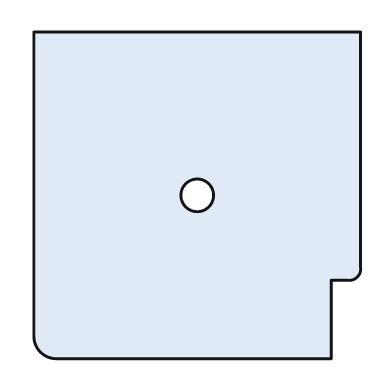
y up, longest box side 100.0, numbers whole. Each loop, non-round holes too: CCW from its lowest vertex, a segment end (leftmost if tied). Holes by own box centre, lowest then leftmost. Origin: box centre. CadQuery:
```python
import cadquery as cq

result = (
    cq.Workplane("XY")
    .moveTo(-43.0, -50.0)
    .lineTo(41.0, -50.0)
    .lineTo(41.0, -26.0)
    .lineTo(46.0, -26.0)
    .threePointArc((49.0, -25.0), (50.0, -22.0))
    .lineTo(50.0, 50.0)
    .lineTo(-50.0, 50.0)
    .lineTo(-50.0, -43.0)
    .threePointArc((-48.0, -48.0), (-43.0, -50.0))
    .close()
    .moveTo(0.0, 0.0)
    .circle(5.0)
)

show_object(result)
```